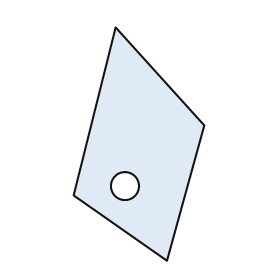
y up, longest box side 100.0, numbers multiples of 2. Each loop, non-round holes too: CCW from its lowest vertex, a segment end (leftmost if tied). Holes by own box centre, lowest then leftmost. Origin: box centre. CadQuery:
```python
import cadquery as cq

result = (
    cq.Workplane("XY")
    .moveTo(12.0, -50.0)
    .lineTo(28.0, 8.0)
    .lineTo(-10.0, 50.0)
    .lineTo(-28.0, -22.0)
    .close()
    .moveTo(-6.0, -18.0)
    .circle(6.0)
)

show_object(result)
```